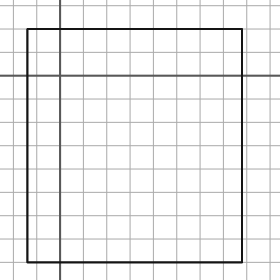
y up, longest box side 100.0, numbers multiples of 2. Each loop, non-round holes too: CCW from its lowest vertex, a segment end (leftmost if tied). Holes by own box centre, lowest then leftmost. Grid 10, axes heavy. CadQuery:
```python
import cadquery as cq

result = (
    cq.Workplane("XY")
    .moveTo(-14.0, -80.0)
    .lineTo(78.0, -80.0)
    .lineTo(78.0, 20.0)
    .lineTo(-14.0, 20.0)
    .close()
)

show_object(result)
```